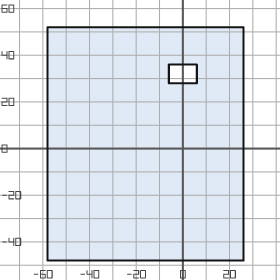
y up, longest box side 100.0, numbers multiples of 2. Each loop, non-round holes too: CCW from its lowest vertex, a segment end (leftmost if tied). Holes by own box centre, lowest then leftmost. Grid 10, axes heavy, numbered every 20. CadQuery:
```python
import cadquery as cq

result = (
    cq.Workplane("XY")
    .moveTo(-58.0, -48.0)
    .lineTo(26.0, -48.0)
    .lineTo(26.0, 52.0)
    .lineTo(-58.0, 52.0)
    .close()
    .moveTo(-6.0, 28.0)
    .lineTo(6.0, 28.0)
    .lineTo(6.0, 36.0)
    .lineTo(-6.0, 36.0)
    .close()
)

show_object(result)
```